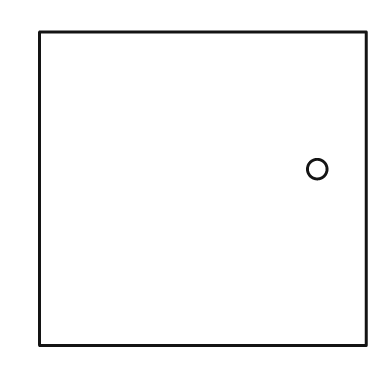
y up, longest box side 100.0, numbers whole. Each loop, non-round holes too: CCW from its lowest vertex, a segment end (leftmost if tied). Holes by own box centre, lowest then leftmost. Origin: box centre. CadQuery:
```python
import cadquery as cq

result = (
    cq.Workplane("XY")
    .moveTo(-50.0, -48.0)
    .lineTo(50.0, -48.0)
    .lineTo(50.0, 48.0)
    .lineTo(-50.0, 48.0)
    .close()
    .moveTo(35.0, 6.0)
    .circle(3.0)
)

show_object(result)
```